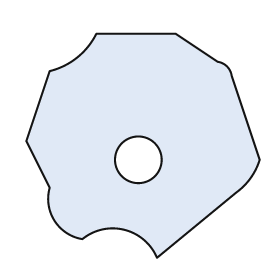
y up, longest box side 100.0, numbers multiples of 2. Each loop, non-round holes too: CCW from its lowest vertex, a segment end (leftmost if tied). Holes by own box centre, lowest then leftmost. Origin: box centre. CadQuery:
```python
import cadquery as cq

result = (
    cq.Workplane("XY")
    .moveTo(6.0, -48.0)
    .lineTo(40.0, -20.0)
    .threePointArc((46.0, -14.0), (50.0, -6.0))
    .lineTo(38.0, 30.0)
    .threePointArc((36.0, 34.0), (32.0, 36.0))
    .lineTo(14.0, 48.0)
    .lineTo(-20.0, 48.0)
    .threePointArc((-28.0, 38.0), (-40.0, 32.0))
    .lineTo(-50.0, 2.0)
    .lineTo(-40.0, -18.0)
    .threePointArc((-38.0, -32.0), (-26.0, -40.0))
    .threePointArc((-8.0, -36.0), (6.0, -48.0))
    .close()
    .moveTo(-2.0, -6.0)
    .circle(10.0)
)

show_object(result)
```